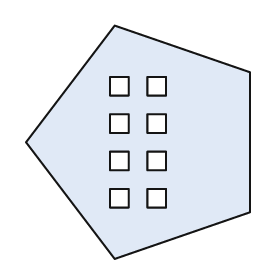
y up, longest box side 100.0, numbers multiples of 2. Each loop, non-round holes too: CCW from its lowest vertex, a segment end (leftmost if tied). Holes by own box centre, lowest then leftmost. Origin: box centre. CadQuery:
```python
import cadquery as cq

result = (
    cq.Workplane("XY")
    .moveTo(-10.0, -50.0)
    .lineTo(48.0, -30.0)
    .lineTo(48.0, 30.0)
    .lineTo(-10.0, 50.0)
    .lineTo(-48.0, 0.0)
    .close()
    .moveTo(-12.0, -28.0)
    .lineTo(-4.0, -28.0)
    .lineTo(-4.0, -20.0)
    .lineTo(-12.0, -20.0)
    .close()
    .moveTo(4.0, -28.0)
    .lineTo(12.0, -28.0)
    .lineTo(12.0, -20.0)
    .lineTo(4.0, -20.0)
    .close()
    .moveTo(-12.0, -12.0)
    .lineTo(-4.0, -12.0)
    .lineTo(-4.0, -4.0)
    .lineTo(-12.0, -4.0)
    .close()
    .moveTo(4.0, -12.0)
    .lineTo(12.0, -12.0)
    .lineTo(12.0, -4.0)
    .lineTo(4.0, -4.0)
    .close()
    .moveTo(-12.0, 4.0)
    .lineTo(-4.0, 4.0)
    .lineTo(-4.0, 12.0)
    .lineTo(-12.0, 12.0)
    .close()
    .moveTo(4.0, 4.0)
    .lineTo(12.0, 4.0)
    .lineTo(12.0, 12.0)
    .lineTo(4.0, 12.0)
    .close()
    .moveTo(-12.0, 20.0)
    .lineTo(-4.0, 20.0)
    .lineTo(-4.0, 28.0)
    .lineTo(-12.0, 28.0)
    .close()
    .moveTo(4.0, 20.0)
    .lineTo(12.0, 20.0)
    .lineTo(12.0, 28.0)
    .lineTo(4.0, 28.0)
    .close()
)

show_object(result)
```